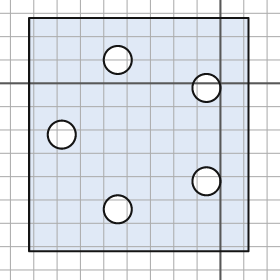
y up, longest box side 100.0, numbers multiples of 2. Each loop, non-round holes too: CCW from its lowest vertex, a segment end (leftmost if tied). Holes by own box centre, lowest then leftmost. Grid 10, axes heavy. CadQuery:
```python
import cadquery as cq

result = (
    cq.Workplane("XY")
    .moveTo(-82.0, -72.0)
    .lineTo(12.0, -72.0)
    .lineTo(12.0, 28.0)
    .lineTo(-82.0, 28.0)
    .close()
    .moveTo(-44.0, -54.0)
    .circle(6.0)
    .moveTo(-6.0, -42.0)
    .circle(6.0)
    .moveTo(-68.0, -22.0)
    .circle(6.0)
    .moveTo(-6.0, -2.0)
    .circle(6.0)
    .moveTo(-44.0, 10.0)
    .circle(6.0)
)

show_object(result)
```